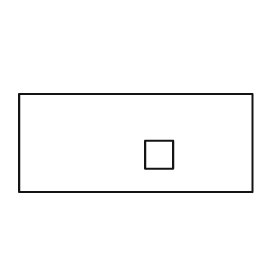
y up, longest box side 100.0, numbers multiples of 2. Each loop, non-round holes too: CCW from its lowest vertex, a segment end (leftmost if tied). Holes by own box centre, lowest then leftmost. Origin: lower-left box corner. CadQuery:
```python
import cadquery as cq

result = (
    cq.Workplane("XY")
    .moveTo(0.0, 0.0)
    .lineTo(100.0, 0.0)
    .lineTo(100.0, 42.0)
    .lineTo(0.0, 42.0)
    .close()
    .moveTo(54.0, 10.0)
    .lineTo(66.0, 10.0)
    .lineTo(66.0, 22.0)
    .lineTo(54.0, 22.0)
    .close()
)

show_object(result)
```